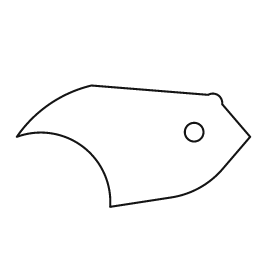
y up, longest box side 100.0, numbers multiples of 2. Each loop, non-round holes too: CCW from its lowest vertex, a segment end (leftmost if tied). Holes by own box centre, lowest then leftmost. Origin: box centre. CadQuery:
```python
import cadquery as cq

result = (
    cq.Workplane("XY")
    .moveTo(-10.0, -26.0)
    .lineTo(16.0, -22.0)
    .threePointArc((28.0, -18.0), (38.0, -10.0))
    .lineTo(50.0, 4.0)
    .lineTo(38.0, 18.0)
    .threePointArc((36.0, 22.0), (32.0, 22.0))
    .lineTo(-18.0, 26.0)
    .threePointArc((-36.0, 18.0), (-50.0, 4.0))
    .threePointArc((-22.0, 0.0), (-10.0, -26.0))
    .close()
    .moveTo(26.0, 6.0)
    .circle(4.0)
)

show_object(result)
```